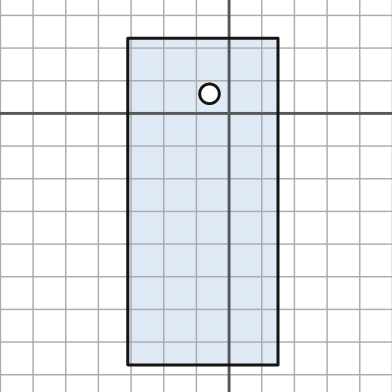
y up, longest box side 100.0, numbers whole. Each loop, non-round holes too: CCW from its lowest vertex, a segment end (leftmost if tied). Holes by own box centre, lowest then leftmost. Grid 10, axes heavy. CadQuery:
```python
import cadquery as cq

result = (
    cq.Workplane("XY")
    .moveTo(-31.0, -77.0)
    .lineTo(15.0, -77.0)
    .lineTo(15.0, 23.0)
    .lineTo(-31.0, 23.0)
    .close()
    .moveTo(-6.0, 6.0)
    .circle(3.0)
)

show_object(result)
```